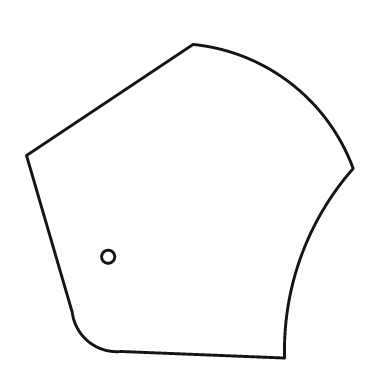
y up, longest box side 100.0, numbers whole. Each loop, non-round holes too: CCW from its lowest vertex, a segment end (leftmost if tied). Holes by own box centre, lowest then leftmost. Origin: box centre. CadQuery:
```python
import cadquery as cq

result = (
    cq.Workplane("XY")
    .moveTo(29.0, -48.0)
    .threePointArc((34.0, -17.0), (50.0, 10.0))
    .threePointArc((31.0, 36.0), (1.0, 48.0))
    .lineTo(-50.0, 14.0)
    .lineTo(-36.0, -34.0)
    .threePointArc((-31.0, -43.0), (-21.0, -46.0))
    .close()
    .moveTo(-25.0, -17.0)
    .circle(2.0)
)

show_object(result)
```